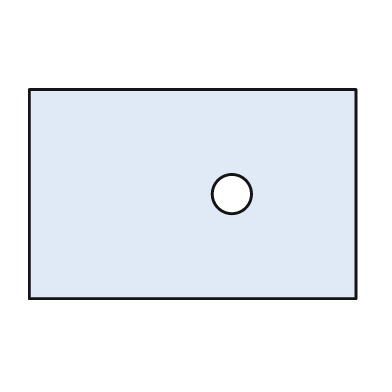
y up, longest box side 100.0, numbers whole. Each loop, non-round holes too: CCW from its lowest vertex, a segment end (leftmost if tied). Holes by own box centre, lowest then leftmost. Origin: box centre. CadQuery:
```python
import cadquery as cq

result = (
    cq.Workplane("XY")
    .moveTo(-50.0, -32.0)
    .lineTo(50.0, -32.0)
    .lineTo(50.0, 32.0)
    .lineTo(-50.0, 32.0)
    .close()
    .moveTo(12.0, 0.0)
    .circle(6.0)
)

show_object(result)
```